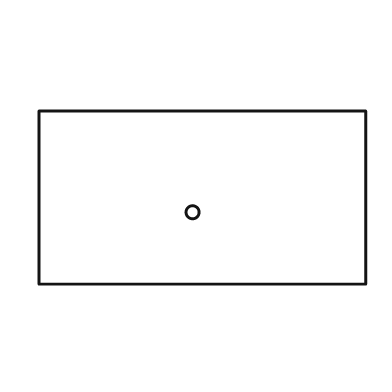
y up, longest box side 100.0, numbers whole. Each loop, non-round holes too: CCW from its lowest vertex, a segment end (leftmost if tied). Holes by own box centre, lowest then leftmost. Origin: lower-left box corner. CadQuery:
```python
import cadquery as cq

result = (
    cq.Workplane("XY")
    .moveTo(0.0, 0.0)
    .lineTo(100.0, 0.0)
    .lineTo(100.0, 53.0)
    .lineTo(0.0, 53.0)
    .close()
    .moveTo(47.0, 22.0)
    .circle(2.0)
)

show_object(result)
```